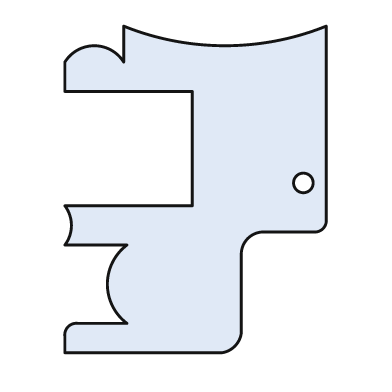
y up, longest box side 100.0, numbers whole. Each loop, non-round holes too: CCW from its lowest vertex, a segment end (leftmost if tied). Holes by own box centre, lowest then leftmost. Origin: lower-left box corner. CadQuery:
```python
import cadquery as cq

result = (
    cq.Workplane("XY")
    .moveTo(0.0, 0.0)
    .lineTo(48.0, 0.0)
    .threePointArc((52.0, 2.0), (54.0, 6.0))
    .lineTo(54.0, 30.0)
    .threePointArc((56.0, 35.0), (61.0, 37.0))
    .lineTo(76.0, 37.0)
    .threePointArc((79.0, 38.0), (80.0, 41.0))
    .lineTo(80.0, 100.0)
    .threePointArc((49.0, 94.0), (18.0, 100.0))
    .lineTo(18.0, 89.0)
    .threePointArc((9.0, 94.0), (0.0, 89.0))
    .lineTo(0.0, 80.0)
    .lineTo(39.0, 80.0)
    .lineTo(39.0, 45.0)
    .lineTo(0.0, 45.0)
    .threePointArc((2.0, 39.0), (0.0, 33.0))
    .lineTo(19.0, 33.0)
    .threePointArc((13.0, 21.0), (19.0, 9.0))
    .lineTo(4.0, 9.0)
    .threePointArc((1.0, 8.0), (0.0, 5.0))
    .close()
    .moveTo(73.0, 52.0)
    .circle(3.0)
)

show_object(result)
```